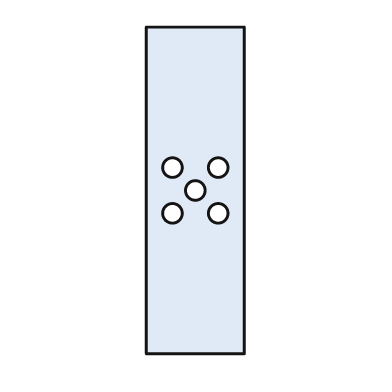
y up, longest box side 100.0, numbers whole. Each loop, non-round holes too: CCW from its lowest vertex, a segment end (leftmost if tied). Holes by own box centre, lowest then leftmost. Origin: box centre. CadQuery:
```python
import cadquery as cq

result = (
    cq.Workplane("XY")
    .moveTo(-15.0, -50.0)
    .lineTo(15.0, -50.0)
    .lineTo(15.0, 50.0)
    .lineTo(-15.0, 50.0)
    .close()
    .moveTo(-7.0, -7.0)
    .circle(3.0)
    .moveTo(7.0, -7.0)
    .circle(3.0)
    .moveTo(0.0, 0.0)
    .circle(3.0)
    .moveTo(-7.0, 7.0)
    .circle(3.0)
    .moveTo(7.0, 7.0)
    .circle(3.0)
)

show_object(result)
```